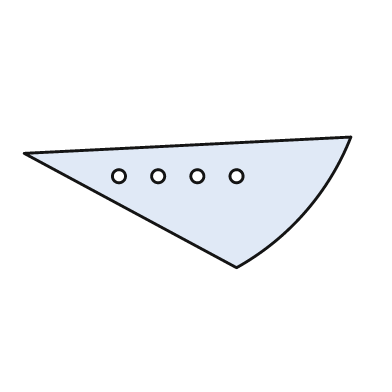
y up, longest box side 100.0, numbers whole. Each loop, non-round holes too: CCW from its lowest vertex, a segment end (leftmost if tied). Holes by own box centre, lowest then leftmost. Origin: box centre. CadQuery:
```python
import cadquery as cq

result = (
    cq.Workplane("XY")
    .moveTo(15.0, -20.0)
    .threePointArc((36.0, -3.0), (50.0, 20.0))
    .lineTo(-50.0, 15.0)
    .close()
    .moveTo(-21.0, 8.0)
    .circle(2.0)
    .moveTo(-9.0, 8.0)
    .circle(2.0)
    .moveTo(3.0, 8.0)
    .circle(2.0)
    .moveTo(15.0, 8.0)
    .circle(2.0)
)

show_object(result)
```